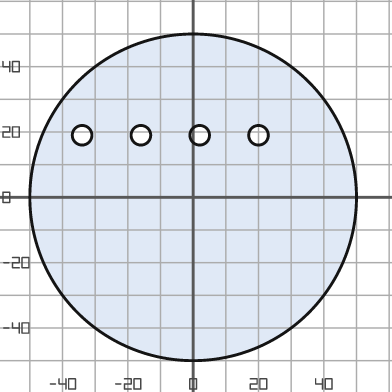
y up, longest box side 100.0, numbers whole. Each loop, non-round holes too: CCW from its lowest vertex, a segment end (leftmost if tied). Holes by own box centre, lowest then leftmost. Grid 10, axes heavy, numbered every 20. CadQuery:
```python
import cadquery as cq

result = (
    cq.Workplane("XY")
    .moveTo(0.0, 0.0)
    .circle(50.0)
    .moveTo(-34.0, 19.0)
    .circle(3.0)
    .moveTo(-16.0, 19.0)
    .circle(3.0)
    .moveTo(2.0, 19.0)
    .circle(3.0)
    .moveTo(20.0, 19.0)
    .circle(3.0)
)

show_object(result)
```